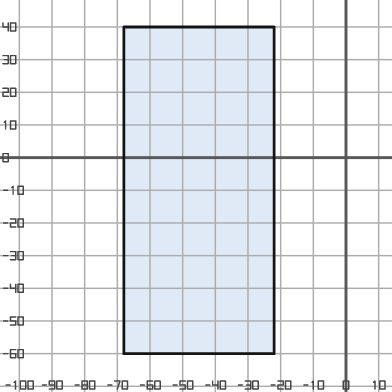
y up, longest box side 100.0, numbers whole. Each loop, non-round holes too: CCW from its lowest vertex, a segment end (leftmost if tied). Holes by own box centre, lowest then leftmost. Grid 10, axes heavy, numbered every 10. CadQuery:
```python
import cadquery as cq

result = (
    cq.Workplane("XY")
    .moveTo(-68.0, -60.0)
    .lineTo(-22.0, -60.0)
    .lineTo(-22.0, 40.0)
    .lineTo(-68.0, 40.0)
    .close()
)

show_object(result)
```